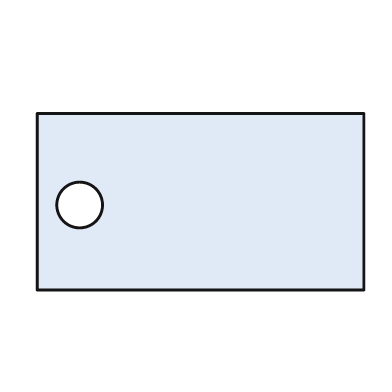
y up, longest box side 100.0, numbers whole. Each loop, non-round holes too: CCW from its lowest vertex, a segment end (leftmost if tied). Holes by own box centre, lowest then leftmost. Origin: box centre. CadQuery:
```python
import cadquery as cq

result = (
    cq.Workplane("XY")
    .moveTo(-50.0, -27.0)
    .lineTo(50.0, -27.0)
    .lineTo(50.0, 27.0)
    .lineTo(-50.0, 27.0)
    .close()
    .moveTo(-37.0, -1.0)
    .circle(7.0)
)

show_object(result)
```